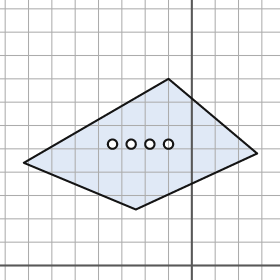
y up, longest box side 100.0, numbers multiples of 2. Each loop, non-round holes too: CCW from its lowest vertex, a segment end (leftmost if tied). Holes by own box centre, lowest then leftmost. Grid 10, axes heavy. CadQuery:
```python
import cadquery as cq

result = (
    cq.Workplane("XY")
    .moveTo(-24.0, 24.0)
    .lineTo(28.0, 48.0)
    .lineTo(-10.0, 80.0)
    .lineTo(-72.0, 44.0)
    .close()
    .moveTo(-34.0, 52.0)
    .circle(2.0)
    .moveTo(-26.0, 52.0)
    .circle(2.0)
    .moveTo(-18.0, 52.0)
    .circle(2.0)
    .moveTo(-10.0, 52.0)
    .circle(2.0)
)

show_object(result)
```